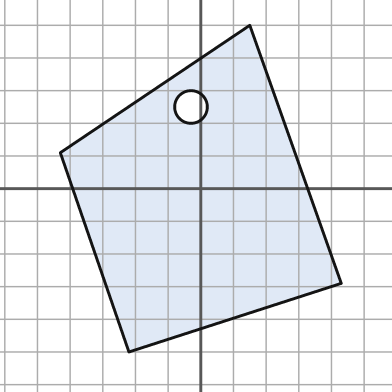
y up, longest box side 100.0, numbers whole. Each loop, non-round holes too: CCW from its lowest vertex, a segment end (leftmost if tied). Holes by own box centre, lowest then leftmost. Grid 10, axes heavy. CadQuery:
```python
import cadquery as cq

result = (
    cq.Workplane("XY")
    .moveTo(-22.0, -50.0)
    .lineTo(43.0, -29.0)
    .lineTo(15.0, 50.0)
    .lineTo(-43.0, 11.0)
    .close()
    .moveTo(-3.0, 25.0)
    .circle(5.0)
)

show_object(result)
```